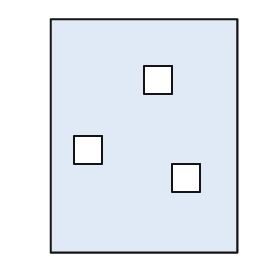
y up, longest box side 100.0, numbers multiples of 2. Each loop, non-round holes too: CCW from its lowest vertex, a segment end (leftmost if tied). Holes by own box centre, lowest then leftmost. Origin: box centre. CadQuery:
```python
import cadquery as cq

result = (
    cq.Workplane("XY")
    .moveTo(-40.0, -50.0)
    .lineTo(40.0, -50.0)
    .lineTo(40.0, 50.0)
    .lineTo(-40.0, 50.0)
    .close()
    .moveTo(12.0, -24.0)
    .lineTo(24.0, -24.0)
    .lineTo(24.0, -12.0)
    .lineTo(12.0, -12.0)
    .close()
    .moveTo(-30.0, -12.0)
    .lineTo(-18.0, -12.0)
    .lineTo(-18.0, 0.0)
    .lineTo(-30.0, 0.0)
    .close()
    .moveTo(0.0, 18.0)
    .lineTo(12.0, 18.0)
    .lineTo(12.0, 30.0)
    .lineTo(0.0, 30.0)
    .close()
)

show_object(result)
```